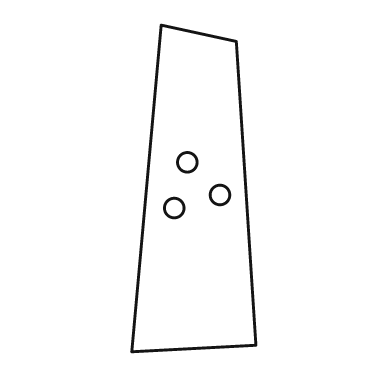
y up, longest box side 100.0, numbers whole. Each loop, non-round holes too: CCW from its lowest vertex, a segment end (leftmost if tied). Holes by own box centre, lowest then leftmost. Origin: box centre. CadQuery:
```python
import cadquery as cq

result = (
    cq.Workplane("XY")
    .moveTo(-19.0, -50.0)
    .lineTo(19.0, -48.0)
    .lineTo(13.0, 45.0)
    .lineTo(-10.0, 50.0)
    .close()
    .moveTo(-6.0, -6.0)
    .circle(3.0)
    .moveTo(8.0, -2.0)
    .circle(3.0)
    .moveTo(-2.0, 8.0)
    .circle(3.0)
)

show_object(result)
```